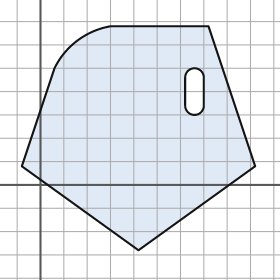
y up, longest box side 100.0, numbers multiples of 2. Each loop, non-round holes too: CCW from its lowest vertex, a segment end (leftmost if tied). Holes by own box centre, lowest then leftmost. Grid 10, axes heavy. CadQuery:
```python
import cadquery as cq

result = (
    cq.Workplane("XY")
    .moveTo(42.0, -28.0)
    .lineTo(92.0, 8.0)
    .lineTo(72.0, 68.0)
    .lineTo(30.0, 68.0)
    .threePointArc((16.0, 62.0), (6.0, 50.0))
    .lineTo(-8.0, 8.0)
    .close()
    .moveTo(62.0, 34.0)
    .threePointArc((66.0, 30.0), (70.0, 34.0))
    .lineTo(70.0, 46.0)
    .threePointArc((66.0, 50.0), (62.0, 46.0))
    .close()
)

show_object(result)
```